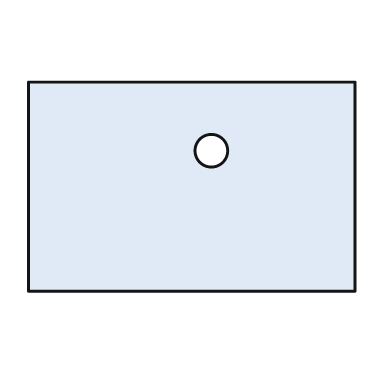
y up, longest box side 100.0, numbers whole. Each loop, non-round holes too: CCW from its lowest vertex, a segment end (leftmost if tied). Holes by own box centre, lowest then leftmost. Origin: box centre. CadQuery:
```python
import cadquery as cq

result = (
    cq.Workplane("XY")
    .moveTo(-50.0, -32.0)
    .lineTo(50.0, -32.0)
    .lineTo(50.0, 32.0)
    .lineTo(-50.0, 32.0)
    .close()
    .moveTo(6.0, 11.0)
    .circle(5.0)
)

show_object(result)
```